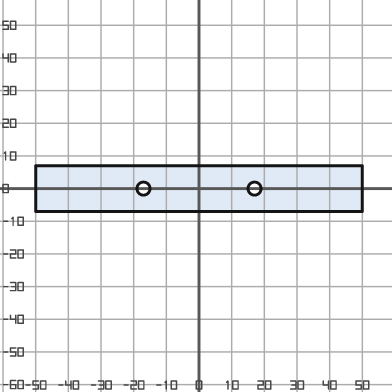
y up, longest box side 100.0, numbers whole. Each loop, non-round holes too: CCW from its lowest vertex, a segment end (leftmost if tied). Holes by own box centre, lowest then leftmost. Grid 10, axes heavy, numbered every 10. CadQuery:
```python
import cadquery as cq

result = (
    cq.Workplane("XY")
    .moveTo(-50.0, -7.0)
    .lineTo(50.0, -7.0)
    .lineTo(50.0, 7.0)
    .lineTo(-50.0, 7.0)
    .close()
    .moveTo(-17.0, 0.0)
    .circle(2.0)
    .moveTo(17.0, 0.0)
    .circle(2.0)
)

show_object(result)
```